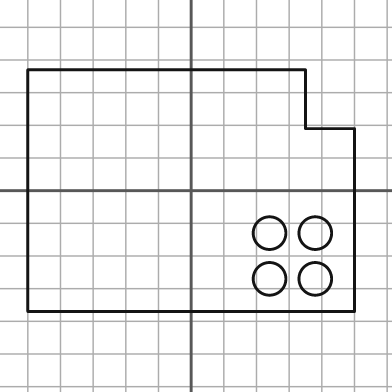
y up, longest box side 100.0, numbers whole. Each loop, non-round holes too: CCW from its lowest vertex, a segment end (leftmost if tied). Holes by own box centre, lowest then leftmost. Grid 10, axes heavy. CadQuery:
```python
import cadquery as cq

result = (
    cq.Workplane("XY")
    .moveTo(-50.0, -37.0)
    .lineTo(50.0, -37.0)
    .lineTo(50.0, 19.0)
    .lineTo(35.0, 19.0)
    .lineTo(35.0, 37.0)
    .lineTo(-50.0, 37.0)
    .close()
    .moveTo(24.0, -27.0)
    .circle(5.0)
    .moveTo(38.0, -27.0)
    .circle(5.0)
    .moveTo(24.0, -13.0)
    .circle(5.0)
    .moveTo(38.0, -13.0)
    .circle(5.0)
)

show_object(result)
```